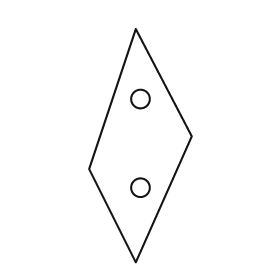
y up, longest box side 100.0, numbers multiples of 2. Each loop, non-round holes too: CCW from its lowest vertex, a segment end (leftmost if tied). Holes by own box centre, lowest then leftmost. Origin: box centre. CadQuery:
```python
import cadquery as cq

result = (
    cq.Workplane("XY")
    .moveTo(-2.0, -50.0)
    .lineTo(22.0, 4.0)
    .lineTo(-2.0, 50.0)
    .lineTo(-22.0, -10.0)
    .close()
    .moveTo(0.0, -18.0)
    .circle(4.0)
    .moveTo(0.0, 20.0)
    .circle(4.0)
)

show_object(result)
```